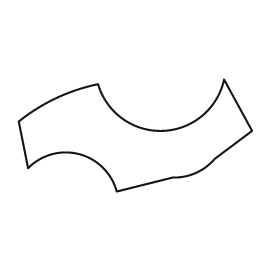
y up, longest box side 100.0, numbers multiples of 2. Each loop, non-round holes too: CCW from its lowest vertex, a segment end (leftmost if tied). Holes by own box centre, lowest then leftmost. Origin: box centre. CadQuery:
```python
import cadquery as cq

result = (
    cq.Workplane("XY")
    .moveTo(-8.0, -24.0)
    .lineTo(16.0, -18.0)
    .threePointArc((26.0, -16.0), (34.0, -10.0))
    .lineTo(50.0, 2.0)
    .lineTo(38.0, 24.0)
    .threePointArc((12.0, 2.0), (-16.0, 22.0))
    .threePointArc((-34.0, 16.0), (-50.0, 6.0))
    .lineTo(-46.0, -14.0)
    .threePointArc((-24.0, -8.0), (-8.0, -24.0))
    .close()
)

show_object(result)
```